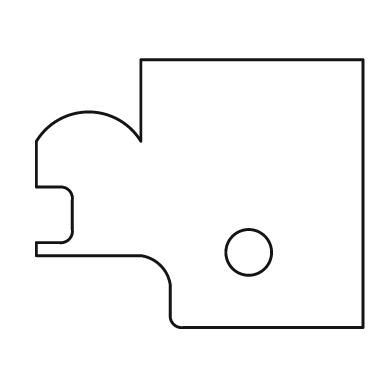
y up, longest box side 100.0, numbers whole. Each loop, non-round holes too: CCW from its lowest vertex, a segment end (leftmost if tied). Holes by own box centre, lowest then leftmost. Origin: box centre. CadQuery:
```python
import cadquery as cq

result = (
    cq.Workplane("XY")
    .moveTo(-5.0, -41.0)
    .lineTo(50.0, -41.0)
    .lineTo(50.0, 41.0)
    .lineTo(-18.0, 41.0)
    .lineTo(-18.0, 16.0)
    .threePointArc((-34.0, 25.0), (-50.0, 16.0))
    .lineTo(-50.0, 2.0)
    .lineTo(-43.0, 2.0)
    .threePointArc((-40.0, 1.0), (-39.0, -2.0))
    .lineTo(-39.0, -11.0)
    .threePointArc((-40.0, -14.0), (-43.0, -15.0))
    .lineTo(-50.0, -15.0)
    .lineTo(-50.0, -19.0)
    .lineTo(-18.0, -19.0)
    .threePointArc((-12.0, -22.0), (-9.0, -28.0))
    .lineTo(-9.0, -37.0)
    .threePointArc((-8.0, -40.0), (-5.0, -41.0))
    .close()
    .moveTo(15.0, -18.0)
    .circle(7.0)
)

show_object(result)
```